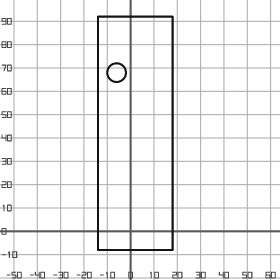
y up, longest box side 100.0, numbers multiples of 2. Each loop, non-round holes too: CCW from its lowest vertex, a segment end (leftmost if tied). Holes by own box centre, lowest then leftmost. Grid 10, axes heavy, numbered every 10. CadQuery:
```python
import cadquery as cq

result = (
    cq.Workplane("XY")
    .moveTo(-14.0, -8.0)
    .lineTo(18.0, -8.0)
    .lineTo(18.0, 92.0)
    .lineTo(-14.0, 92.0)
    .close()
    .moveTo(-6.0, 68.0)
    .circle(4.0)
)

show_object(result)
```